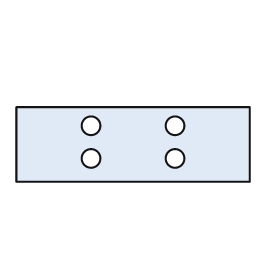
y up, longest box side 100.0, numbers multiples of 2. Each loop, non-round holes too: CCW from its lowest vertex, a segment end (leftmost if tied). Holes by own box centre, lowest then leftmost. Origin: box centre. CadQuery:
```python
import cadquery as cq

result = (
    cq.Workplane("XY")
    .moveTo(-50.0, -16.0)
    .lineTo(50.0, -16.0)
    .lineTo(50.0, 16.0)
    .lineTo(-50.0, 16.0)
    .close()
    .moveTo(-18.0, -6.0)
    .circle(4.0)
    .moveTo(18.0, -6.0)
    .circle(4.0)
    .moveTo(-18.0, 8.0)
    .circle(4.0)
    .moveTo(18.0, 8.0)
    .circle(4.0)
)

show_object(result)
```